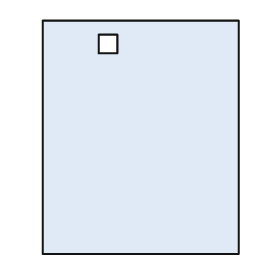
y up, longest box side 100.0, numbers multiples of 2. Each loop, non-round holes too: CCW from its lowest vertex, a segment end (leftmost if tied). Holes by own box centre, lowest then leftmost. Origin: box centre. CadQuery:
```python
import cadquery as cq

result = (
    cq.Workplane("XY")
    .moveTo(-42.0, -50.0)
    .lineTo(42.0, -50.0)
    .lineTo(42.0, 50.0)
    .lineTo(-42.0, 50.0)
    .close()
    .moveTo(-18.0, 36.0)
    .lineTo(-10.0, 36.0)
    .lineTo(-10.0, 44.0)
    .lineTo(-18.0, 44.0)
    .close()
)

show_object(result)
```